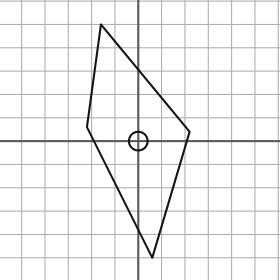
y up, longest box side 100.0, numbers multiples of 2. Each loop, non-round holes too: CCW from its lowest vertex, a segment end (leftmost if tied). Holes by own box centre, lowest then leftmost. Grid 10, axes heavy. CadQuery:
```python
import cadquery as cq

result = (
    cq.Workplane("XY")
    .moveTo(6.0, -50.0)
    .lineTo(22.0, 4.0)
    .lineTo(-16.0, 50.0)
    .lineTo(-22.0, 6.0)
    .close()
    .moveTo(0.0, 0.0)
    .circle(4.0)
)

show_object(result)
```